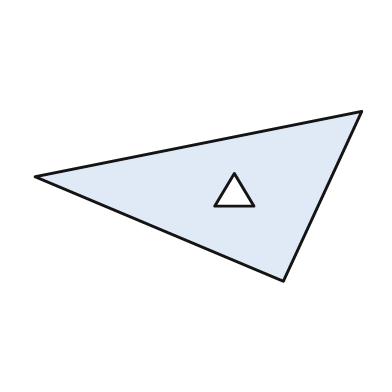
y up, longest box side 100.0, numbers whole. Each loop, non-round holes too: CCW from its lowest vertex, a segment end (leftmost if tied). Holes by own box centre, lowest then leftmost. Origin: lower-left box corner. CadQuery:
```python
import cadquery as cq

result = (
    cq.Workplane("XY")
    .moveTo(76.0, 0.0)
    .lineTo(100.0, 52.0)
    .lineTo(0.0, 32.0)
    .close()
    .moveTo(55.0, 23.0)
    .lineTo(67.0, 23.0)
    .lineTo(61.0, 33.0)
    .close()
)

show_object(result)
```